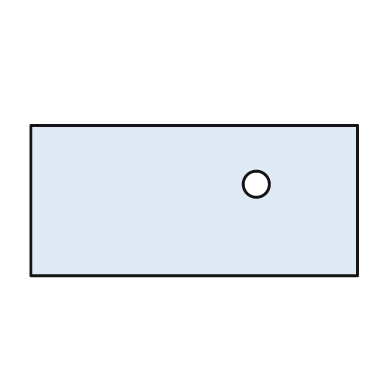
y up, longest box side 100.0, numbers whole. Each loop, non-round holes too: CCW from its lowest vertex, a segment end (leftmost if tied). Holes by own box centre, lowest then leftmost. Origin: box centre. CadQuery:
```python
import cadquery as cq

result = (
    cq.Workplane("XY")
    .moveTo(-50.0, -23.0)
    .lineTo(50.0, -23.0)
    .lineTo(50.0, 23.0)
    .lineTo(-50.0, 23.0)
    .close()
    .moveTo(19.0, 5.0)
    .circle(4.0)
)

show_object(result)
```